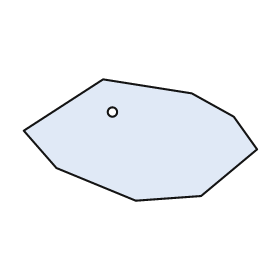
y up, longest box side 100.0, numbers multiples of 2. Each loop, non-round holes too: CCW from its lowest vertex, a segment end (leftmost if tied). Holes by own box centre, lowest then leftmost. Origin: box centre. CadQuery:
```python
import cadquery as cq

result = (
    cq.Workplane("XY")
    .moveTo(-2.0, -26.0)
    .lineTo(26.0, -24.0)
    .lineTo(50.0, -4.0)
    .lineTo(40.0, 10.0)
    .lineTo(22.0, 20.0)
    .lineTo(-16.0, 26.0)
    .lineTo(-50.0, 4.0)
    .lineTo(-36.0, -12.0)
    .close()
    .moveTo(-12.0, 12.0)
    .circle(2.0)
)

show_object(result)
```